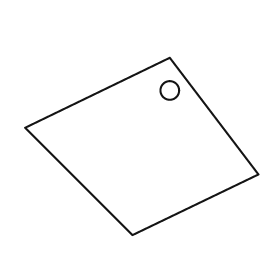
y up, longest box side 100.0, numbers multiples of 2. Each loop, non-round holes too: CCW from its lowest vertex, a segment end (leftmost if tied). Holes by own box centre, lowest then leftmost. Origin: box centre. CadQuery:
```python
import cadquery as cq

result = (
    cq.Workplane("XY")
    .moveTo(-4.0, -38.0)
    .lineTo(50.0, -12.0)
    .lineTo(12.0, 38.0)
    .lineTo(-50.0, 8.0)
    .close()
    .moveTo(12.0, 24.0)
    .circle(4.0)
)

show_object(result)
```